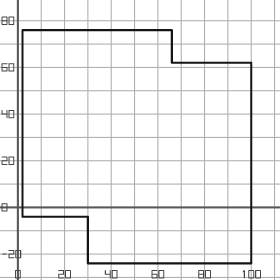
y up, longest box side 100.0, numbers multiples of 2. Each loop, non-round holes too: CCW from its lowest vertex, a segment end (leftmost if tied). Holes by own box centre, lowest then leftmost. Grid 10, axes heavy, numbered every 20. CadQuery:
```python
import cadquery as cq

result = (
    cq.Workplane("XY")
    .moveTo(30.0, -24.0)
    .lineTo(100.0, -24.0)
    .lineTo(100.0, 62.0)
    .lineTo(66.0, 62.0)
    .lineTo(66.0, 76.0)
    .lineTo(2.0, 76.0)
    .lineTo(2.0, -4.0)
    .lineTo(30.0, -4.0)
    .close()
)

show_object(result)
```